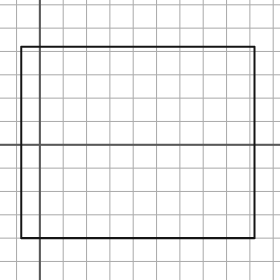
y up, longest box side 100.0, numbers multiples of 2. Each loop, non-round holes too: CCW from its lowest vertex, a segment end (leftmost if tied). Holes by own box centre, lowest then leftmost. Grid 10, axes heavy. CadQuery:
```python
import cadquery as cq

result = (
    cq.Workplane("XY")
    .moveTo(-8.0, -40.0)
    .lineTo(92.0, -40.0)
    .lineTo(92.0, 42.0)
    .lineTo(-8.0, 42.0)
    .close()
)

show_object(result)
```